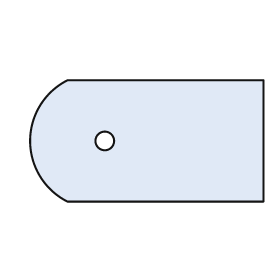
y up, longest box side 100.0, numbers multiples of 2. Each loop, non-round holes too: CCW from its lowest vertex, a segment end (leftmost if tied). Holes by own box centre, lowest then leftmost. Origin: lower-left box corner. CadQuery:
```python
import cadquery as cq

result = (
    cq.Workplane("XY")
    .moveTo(16.0, 0.0)
    .lineTo(100.0, 0.0)
    .lineTo(100.0, 52.0)
    .lineTo(16.0, 52.0)
    .threePointArc((0.0, 26.0), (16.0, 0.0))
    .close()
    .moveTo(32.0, 26.0)
    .circle(4.0)
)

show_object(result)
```